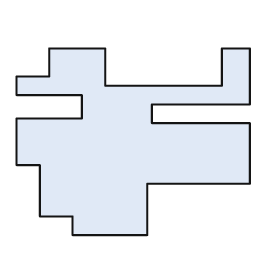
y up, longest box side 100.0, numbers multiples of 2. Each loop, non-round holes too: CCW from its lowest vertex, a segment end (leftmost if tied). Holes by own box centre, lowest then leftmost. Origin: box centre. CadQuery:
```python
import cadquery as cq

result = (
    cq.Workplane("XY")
    .moveTo(-26.0, -40.0)
    .lineTo(6.0, -40.0)
    .lineTo(6.0, -18.0)
    .lineTo(50.0, -18.0)
    .lineTo(50.0, 8.0)
    .lineTo(8.0, 8.0)
    .lineTo(8.0, 16.0)
    .lineTo(50.0, 16.0)
    .lineTo(50.0, 40.0)
    .lineTo(38.0, 40.0)
    .lineTo(38.0, 24.0)
    .lineTo(-12.0, 24.0)
    .lineTo(-12.0, 40.0)
    .lineTo(-36.0, 40.0)
    .lineTo(-36.0, 28.0)
    .lineTo(-50.0, 28.0)
    .lineTo(-50.0, 20.0)
    .lineTo(-22.0, 20.0)
    .lineTo(-22.0, 10.0)
    .lineTo(-50.0, 10.0)
    .lineTo(-50.0, -10.0)
    .lineTo(-40.0, -10.0)
    .lineTo(-40.0, -32.0)
    .lineTo(-26.0, -32.0)
    .close()
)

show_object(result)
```